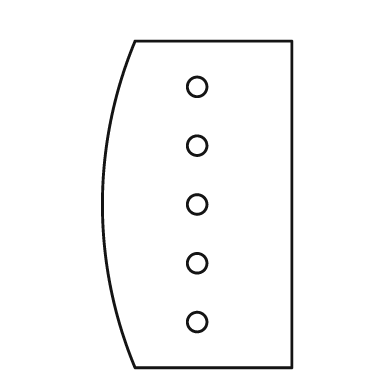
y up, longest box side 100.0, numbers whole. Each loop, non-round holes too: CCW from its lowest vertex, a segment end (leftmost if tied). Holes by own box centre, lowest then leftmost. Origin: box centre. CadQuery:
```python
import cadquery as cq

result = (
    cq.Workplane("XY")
    .moveTo(-19.0, -50.0)
    .lineTo(29.0, -50.0)
    .lineTo(29.0, 50.0)
    .lineTo(-19.0, 50.0)
    .threePointArc((-29.0, 0.0), (-19.0, -50.0))
    .close()
    .moveTo(0.0, -36.0)
    .circle(3.0)
    .moveTo(0.0, -18.0)
    .circle(3.0)
    .moveTo(0.0, 0.0)
    .circle(3.0)
    .moveTo(0.0, 18.0)
    .circle(3.0)
    .moveTo(0.0, 36.0)
    .circle(3.0)
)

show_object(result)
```